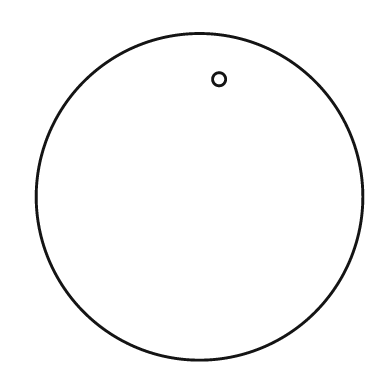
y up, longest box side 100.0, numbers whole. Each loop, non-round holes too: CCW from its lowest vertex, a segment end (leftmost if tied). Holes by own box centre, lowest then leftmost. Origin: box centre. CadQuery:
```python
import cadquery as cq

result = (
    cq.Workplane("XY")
    .moveTo(0.0, 0.0)
    .circle(50.0)
    .moveTo(6.0, 36.0)
    .circle(2.0)
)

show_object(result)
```